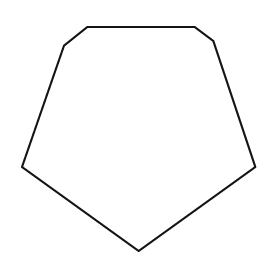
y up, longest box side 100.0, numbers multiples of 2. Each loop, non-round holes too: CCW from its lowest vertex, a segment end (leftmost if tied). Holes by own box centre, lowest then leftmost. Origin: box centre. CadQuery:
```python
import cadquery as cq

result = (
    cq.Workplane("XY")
    .moveTo(0.0, -48.0)
    .lineTo(50.0, -12.0)
    .lineTo(32.0, 42.0)
    .lineTo(24.0, 48.0)
    .lineTo(-22.0, 48.0)
    .lineTo(-32.0, 40.0)
    .lineTo(-50.0, -12.0)
    .close()
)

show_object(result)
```